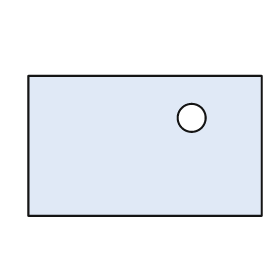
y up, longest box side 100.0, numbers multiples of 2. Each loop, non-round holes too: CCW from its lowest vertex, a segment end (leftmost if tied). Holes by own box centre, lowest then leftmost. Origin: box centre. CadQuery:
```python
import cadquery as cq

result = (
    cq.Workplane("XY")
    .moveTo(-50.0, -30.0)
    .lineTo(50.0, -30.0)
    .lineTo(50.0, 30.0)
    .lineTo(-50.0, 30.0)
    .close()
    .moveTo(20.0, 12.0)
    .circle(6.0)
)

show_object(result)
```